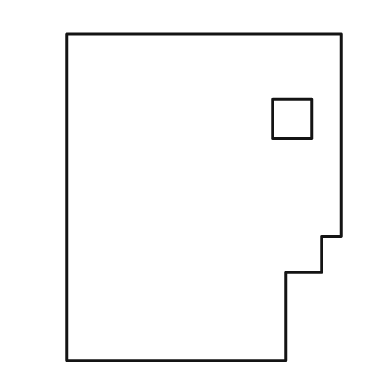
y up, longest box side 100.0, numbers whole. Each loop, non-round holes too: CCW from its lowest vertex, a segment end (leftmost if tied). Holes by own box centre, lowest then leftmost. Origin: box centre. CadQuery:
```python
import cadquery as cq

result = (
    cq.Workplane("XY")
    .moveTo(-42.0, -50.0)
    .lineTo(25.0, -50.0)
    .lineTo(25.0, -23.0)
    .lineTo(36.0, -23.0)
    .lineTo(36.0, -12.0)
    .lineTo(42.0, -12.0)
    .lineTo(42.0, 50.0)
    .lineTo(-42.0, 50.0)
    .close()
    .moveTo(21.0, 18.0)
    .lineTo(33.0, 18.0)
    .lineTo(33.0, 30.0)
    .lineTo(21.0, 30.0)
    .close()
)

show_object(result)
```